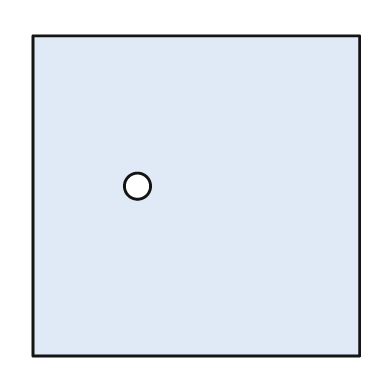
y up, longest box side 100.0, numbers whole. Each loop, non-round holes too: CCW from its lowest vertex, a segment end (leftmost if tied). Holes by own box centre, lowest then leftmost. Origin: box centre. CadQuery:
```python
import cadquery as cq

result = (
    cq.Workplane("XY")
    .moveTo(-50.0, -49.0)
    .lineTo(50.0, -49.0)
    .lineTo(50.0, 49.0)
    .lineTo(-50.0, 49.0)
    .close()
    .moveTo(-18.0, 3.0)
    .circle(4.0)
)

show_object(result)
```